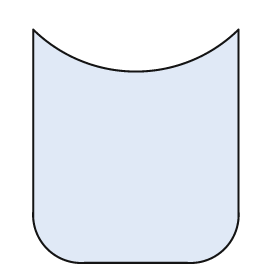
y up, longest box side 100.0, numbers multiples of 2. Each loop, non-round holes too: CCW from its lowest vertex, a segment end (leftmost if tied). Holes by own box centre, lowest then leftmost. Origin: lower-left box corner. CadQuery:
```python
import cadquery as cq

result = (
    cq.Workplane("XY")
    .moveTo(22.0, 0.0)
    .lineTo(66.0, 0.0)
    .threePointArc((82.0, 6.0), (88.0, 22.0))
    .lineTo(88.0, 100.0)
    .threePointArc((44.0, 82.0), (0.0, 100.0))
    .lineTo(0.0, 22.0)
    .threePointArc((6.0, 6.0), (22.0, 0.0))
    .close()
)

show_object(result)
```